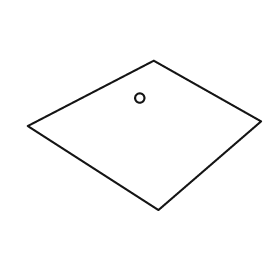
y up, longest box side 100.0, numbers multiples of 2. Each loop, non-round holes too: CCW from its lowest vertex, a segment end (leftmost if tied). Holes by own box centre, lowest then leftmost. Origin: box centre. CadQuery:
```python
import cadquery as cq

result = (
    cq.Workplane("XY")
    .moveTo(6.0, -32.0)
    .lineTo(50.0, 6.0)
    .lineTo(4.0, 32.0)
    .lineTo(-50.0, 4.0)
    .close()
    .moveTo(-2.0, 16.0)
    .circle(2.0)
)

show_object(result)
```